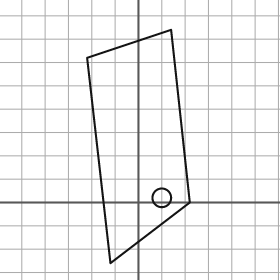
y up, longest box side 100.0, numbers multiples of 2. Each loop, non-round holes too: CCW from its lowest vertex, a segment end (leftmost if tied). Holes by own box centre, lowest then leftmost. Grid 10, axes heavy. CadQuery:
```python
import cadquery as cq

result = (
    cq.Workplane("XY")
    .moveTo(-12.0, -26.0)
    .lineTo(22.0, 0.0)
    .lineTo(14.0, 74.0)
    .lineTo(-22.0, 62.0)
    .close()
    .moveTo(10.0, 2.0)
    .circle(4.0)
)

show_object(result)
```